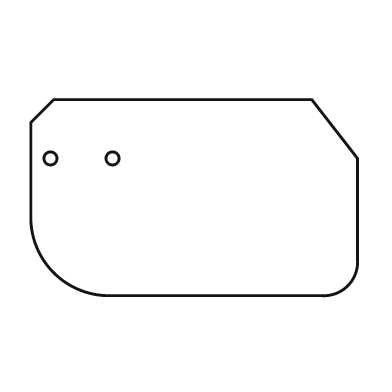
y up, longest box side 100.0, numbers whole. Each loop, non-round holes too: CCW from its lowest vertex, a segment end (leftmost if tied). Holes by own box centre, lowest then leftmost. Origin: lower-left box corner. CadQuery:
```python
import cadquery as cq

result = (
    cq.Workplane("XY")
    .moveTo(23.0, 0.0)
    .lineTo(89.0, 0.0)
    .threePointArc((97.0, 3.0), (100.0, 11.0))
    .lineTo(100.0, 42.0)
    .lineTo(86.0, 60.0)
    .lineTo(7.0, 60.0)
    .lineTo(0.0, 53.0)
    .lineTo(0.0, 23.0)
    .threePointArc((7.0, 7.0), (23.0, 0.0))
    .close()
    .moveTo(6.0, 42.0)
    .circle(2.0)
    .moveTo(25.0, 42.0)
    .circle(2.0)
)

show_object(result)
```